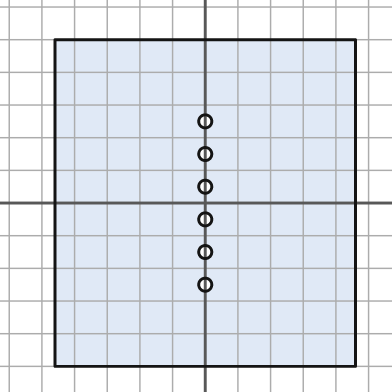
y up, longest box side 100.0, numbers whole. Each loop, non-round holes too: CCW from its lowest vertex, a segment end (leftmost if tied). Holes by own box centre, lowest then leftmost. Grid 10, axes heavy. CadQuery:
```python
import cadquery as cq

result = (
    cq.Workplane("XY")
    .moveTo(-46.0, -50.0)
    .lineTo(46.0, -50.0)
    .lineTo(46.0, 50.0)
    .lineTo(-46.0, 50.0)
    .close()
    .moveTo(0.0, -25.0)
    .circle(2.0)
    .moveTo(0.0, -15.0)
    .circle(2.0)
    .moveTo(0.0, -5.0)
    .circle(2.0)
    .moveTo(0.0, 5.0)
    .circle(2.0)
    .moveTo(0.0, 15.0)
    .circle(2.0)
    .moveTo(0.0, 25.0)
    .circle(2.0)
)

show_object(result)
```